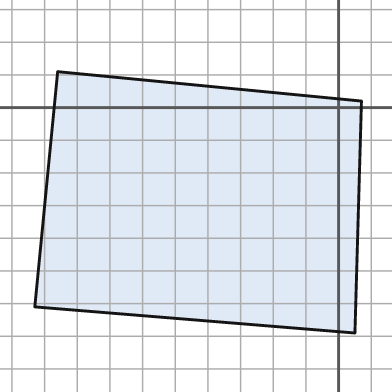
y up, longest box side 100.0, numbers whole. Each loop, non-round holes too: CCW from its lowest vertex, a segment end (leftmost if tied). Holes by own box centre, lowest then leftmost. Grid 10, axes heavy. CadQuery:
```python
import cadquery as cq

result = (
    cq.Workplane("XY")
    .moveTo(5.0, -69.0)
    .lineTo(7.0, 2.0)
    .lineTo(-86.0, 11.0)
    .lineTo(-93.0, -61.0)
    .close()
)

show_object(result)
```